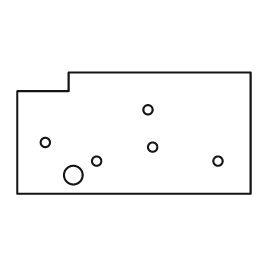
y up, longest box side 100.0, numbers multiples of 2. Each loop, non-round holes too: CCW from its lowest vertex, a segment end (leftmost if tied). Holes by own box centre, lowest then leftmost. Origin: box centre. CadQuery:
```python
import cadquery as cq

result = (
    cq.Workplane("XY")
    .moveTo(-50.0, -26.0)
    .lineTo(50.0, -26.0)
    .lineTo(50.0, 26.0)
    .lineTo(-28.0, 26.0)
    .lineTo(-28.0, 18.0)
    .lineTo(-50.0, 18.0)
    .close()
    .moveTo(-26.0, -18.0)
    .circle(4.0)
    .moveTo(-16.0, -12.0)
    .circle(2.0)
    .moveTo(36.0, -12.0)
    .circle(2.0)
    .moveTo(8.0, -6.0)
    .circle(2.0)
    .moveTo(-38.0, -4.0)
    .circle(2.0)
    .moveTo(6.0, 10.0)
    .circle(2.0)
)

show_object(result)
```